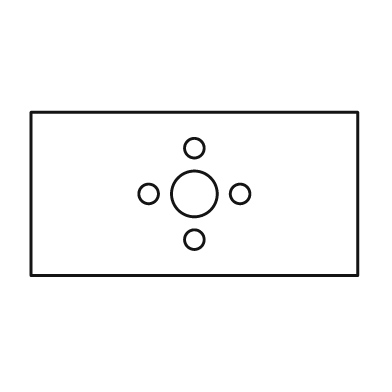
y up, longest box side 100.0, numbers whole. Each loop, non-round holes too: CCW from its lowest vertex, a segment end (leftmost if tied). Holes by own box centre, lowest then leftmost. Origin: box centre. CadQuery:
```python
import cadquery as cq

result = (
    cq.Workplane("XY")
    .moveTo(-50.0, -25.0)
    .lineTo(50.0, -25.0)
    .lineTo(50.0, 25.0)
    .lineTo(-50.0, 25.0)
    .close()
    .moveTo(0.0, -14.0)
    .circle(3.0)
    .moveTo(-14.0, 0.0)
    .circle(3.0)
    .moveTo(0.0, 0.0)
    .circle(7.0)
    .moveTo(14.0, 0.0)
    .circle(3.0)
    .moveTo(0.0, 14.0)
    .circle(3.0)
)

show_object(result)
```